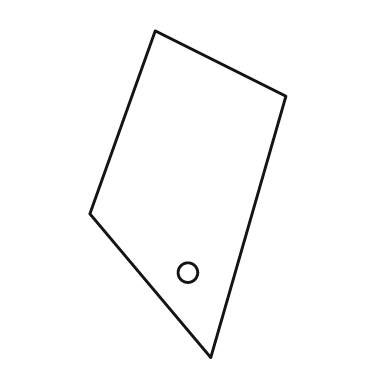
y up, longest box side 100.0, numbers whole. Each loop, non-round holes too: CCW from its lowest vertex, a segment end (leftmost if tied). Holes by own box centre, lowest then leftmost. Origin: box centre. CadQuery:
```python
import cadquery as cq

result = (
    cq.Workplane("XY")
    .moveTo(7.0, -50.0)
    .lineTo(30.0, 30.0)
    .lineTo(-10.0, 50.0)
    .lineTo(-30.0, -6.0)
    .close()
    .moveTo(0.0, -24.0)
    .circle(3.0)
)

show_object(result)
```